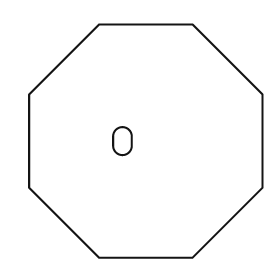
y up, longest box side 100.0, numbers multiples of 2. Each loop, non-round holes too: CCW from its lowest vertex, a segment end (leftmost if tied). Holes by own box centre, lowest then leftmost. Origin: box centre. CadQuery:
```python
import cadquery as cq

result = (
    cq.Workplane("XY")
    .moveTo(-20.0, -50.0)
    .lineTo(20.0, -50.0)
    .lineTo(50.0, -20.0)
    .lineTo(50.0, 20.0)
    .lineTo(20.0, 50.0)
    .lineTo(-20.0, 50.0)
    .lineTo(-50.0, 20.0)
    .lineTo(-50.0, -20.0)
    .close()
    .moveTo(-14.0, -2.0)
    .threePointArc((-10.0, -6.0), (-6.0, -2.0))
    .lineTo(-6.0, 2.0)
    .threePointArc((-10.0, 6.0), (-14.0, 2.0))
    .close()
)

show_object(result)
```